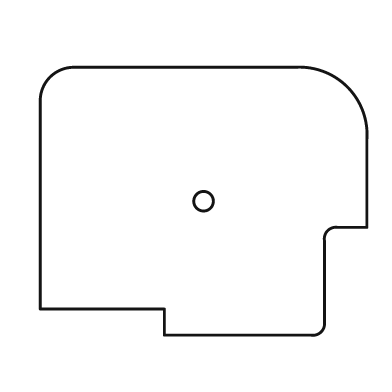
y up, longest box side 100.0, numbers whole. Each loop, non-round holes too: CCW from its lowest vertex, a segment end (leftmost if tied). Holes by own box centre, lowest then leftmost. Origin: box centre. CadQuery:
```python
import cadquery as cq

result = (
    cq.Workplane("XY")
    .moveTo(-12.0, -41.0)
    .lineTo(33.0, -41.0)
    .threePointArc((36.0, -40.0), (37.0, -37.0))
    .lineTo(37.0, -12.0)
    .threePointArc((38.0, -9.0), (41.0, -8.0))
    .lineTo(50.0, -8.0)
    .lineTo(50.0, 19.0)
    .threePointArc((44.0, 35.0), (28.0, 41.0))
    .lineTo(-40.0, 41.0)
    .threePointArc((-47.0, 38.0), (-50.0, 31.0))
    .lineTo(-50.0, -33.0)
    .lineTo(-12.0, -33.0)
    .close()
    .moveTo(0.0, 0.0)
    .circle(3.0)
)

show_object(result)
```